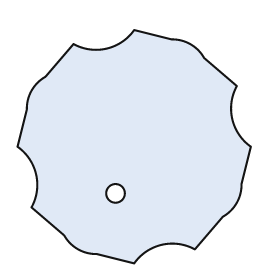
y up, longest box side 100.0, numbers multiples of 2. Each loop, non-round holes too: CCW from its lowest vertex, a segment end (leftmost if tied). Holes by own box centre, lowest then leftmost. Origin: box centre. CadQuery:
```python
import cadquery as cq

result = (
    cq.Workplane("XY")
    .moveTo(0.0, -50.0)
    .threePointArc((12.0, -42.0), (26.0, -44.0))
    .lineTo(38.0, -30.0)
    .threePointArc((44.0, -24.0), (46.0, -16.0))
    .lineTo(50.0, 0.0)
    .threePointArc((42.0, 12.0), (44.0, 26.0))
    .lineTo(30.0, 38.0)
    .threePointArc((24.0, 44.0), (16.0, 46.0))
    .lineTo(0.0, 50.0)
    .threePointArc((-12.0, 42.0), (-26.0, 44.0))
    .lineTo(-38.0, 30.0)
    .threePointArc((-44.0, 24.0), (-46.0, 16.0))
    .lineTo(-50.0, 0.0)
    .threePointArc((-42.0, -12.0), (-44.0, -26.0))
    .lineTo(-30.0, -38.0)
    .threePointArc((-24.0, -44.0), (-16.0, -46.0))
    .close()
    .moveTo(-8.0, -20.0)
    .circle(4.0)
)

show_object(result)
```